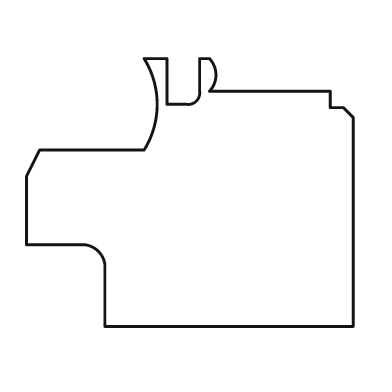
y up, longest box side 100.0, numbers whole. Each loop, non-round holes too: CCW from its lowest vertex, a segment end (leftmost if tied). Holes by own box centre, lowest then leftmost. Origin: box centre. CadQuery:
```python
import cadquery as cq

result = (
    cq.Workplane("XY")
    .moveTo(-26.0, -41.0)
    .lineTo(50.0, -41.0)
    .lineTo(50.0, 23.0)
    .lineTo(47.0, 26.0)
    .lineTo(43.0, 26.0)
    .lineTo(43.0, 31.0)
    .lineTo(6.0, 31.0)
    .threePointArc((8.0, 36.0), (6.0, 41.0))
    .lineTo(3.0, 41.0)
    .lineTo(3.0, 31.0)
    .threePointArc((2.0, 28.0), (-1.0, 27.0))
    .lineTo(-7.0, 27.0)
    .lineTo(-7.0, 41.0)
    .lineTo(-14.0, 41.0)
    .threePointArc((-10.0, 27.0), (-14.0, 13.0))
    .lineTo(-46.0, 13.0)
    .lineTo(-50.0, 5.0)
    .lineTo(-50.0, -16.0)
    .lineTo(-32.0, -16.0)
    .threePointArc((-28.0, -18.0), (-26.0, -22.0))
    .close()
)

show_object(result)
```